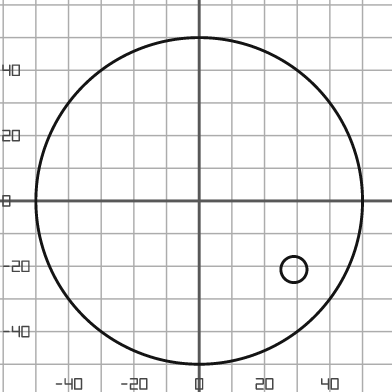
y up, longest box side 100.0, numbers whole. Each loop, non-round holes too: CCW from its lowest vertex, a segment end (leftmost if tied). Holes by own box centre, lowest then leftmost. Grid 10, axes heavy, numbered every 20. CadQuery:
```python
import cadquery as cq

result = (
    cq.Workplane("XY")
    .moveTo(0.0, 0.0)
    .circle(50.0)
    .moveTo(29.0, -21.0)
    .circle(4.0)
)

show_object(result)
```